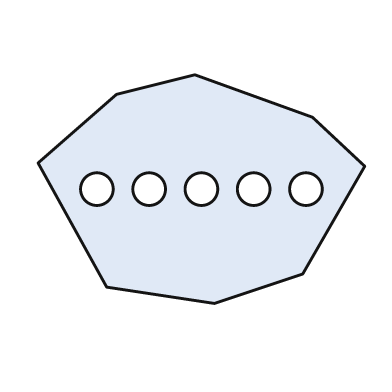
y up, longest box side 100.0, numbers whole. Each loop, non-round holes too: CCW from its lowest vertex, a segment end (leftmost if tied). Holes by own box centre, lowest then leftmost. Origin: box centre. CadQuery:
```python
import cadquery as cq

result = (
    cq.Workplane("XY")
    .moveTo(4.0, -35.0)
    .lineTo(31.0, -26.0)
    .lineTo(50.0, 7.0)
    .lineTo(34.0, 22.0)
    .lineTo(-2.0, 35.0)
    .lineTo(-26.0, 29.0)
    .lineTo(-50.0, 8.0)
    .lineTo(-29.0, -30.0)
    .close()
    .moveTo(-32.0, 0.0)
    .circle(5.0)
    .moveTo(-16.0, 0.0)
    .circle(5.0)
    .moveTo(0.0, 0.0)
    .circle(5.0)
    .moveTo(16.0, 0.0)
    .circle(5.0)
    .moveTo(32.0, 0.0)
    .circle(5.0)
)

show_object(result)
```